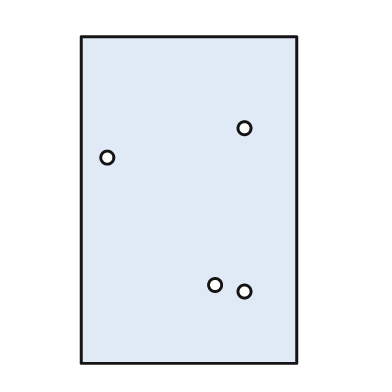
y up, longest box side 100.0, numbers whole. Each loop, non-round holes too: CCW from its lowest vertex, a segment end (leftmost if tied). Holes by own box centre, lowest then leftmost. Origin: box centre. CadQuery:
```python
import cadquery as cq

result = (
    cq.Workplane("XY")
    .moveTo(-33.0, -50.0)
    .lineTo(33.0, -50.0)
    .lineTo(33.0, 50.0)
    .lineTo(-33.0, 50.0)
    .close()
    .moveTo(17.0, -28.0)
    .circle(2.0)
    .moveTo(8.0, -26.0)
    .circle(2.0)
    .moveTo(-25.0, 13.0)
    .circle(2.0)
    .moveTo(17.0, 22.0)
    .circle(2.0)
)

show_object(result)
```